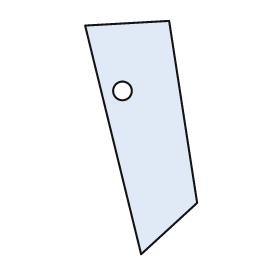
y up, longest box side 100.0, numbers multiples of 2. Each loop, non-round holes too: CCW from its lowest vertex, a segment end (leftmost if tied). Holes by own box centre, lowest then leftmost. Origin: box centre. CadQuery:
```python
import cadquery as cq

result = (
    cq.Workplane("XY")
    .moveTo(0.0, -50.0)
    .lineTo(24.0, -28.0)
    .lineTo(12.0, 50.0)
    .lineTo(-24.0, 48.0)
    .close()
    .moveTo(-8.0, 20.0)
    .circle(4.0)
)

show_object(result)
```